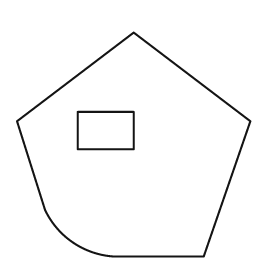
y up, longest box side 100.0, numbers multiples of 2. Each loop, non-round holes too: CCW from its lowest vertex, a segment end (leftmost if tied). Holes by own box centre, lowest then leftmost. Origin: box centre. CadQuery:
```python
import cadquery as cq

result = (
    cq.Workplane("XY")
    .moveTo(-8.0, -48.0)
    .lineTo(30.0, -48.0)
    .lineTo(50.0, 10.0)
    .lineTo(0.0, 48.0)
    .lineTo(-50.0, 10.0)
    .lineTo(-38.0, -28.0)
    .threePointArc((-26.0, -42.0), (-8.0, -48.0))
    .close()
    .moveTo(-24.0, -2.0)
    .lineTo(0.0, -2.0)
    .lineTo(0.0, 14.0)
    .lineTo(-24.0, 14.0)
    .close()
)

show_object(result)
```